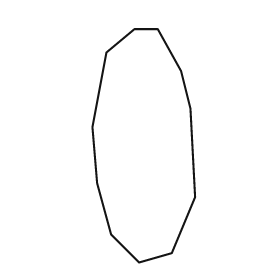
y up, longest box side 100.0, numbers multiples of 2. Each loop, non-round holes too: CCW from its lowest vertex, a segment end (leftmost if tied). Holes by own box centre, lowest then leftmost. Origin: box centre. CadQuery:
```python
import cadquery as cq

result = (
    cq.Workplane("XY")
    .moveTo(-2.0, -50.0)
    .lineTo(12.0, -46.0)
    .lineTo(22.0, -22.0)
    .lineTo(20.0, 16.0)
    .lineTo(16.0, 32.0)
    .lineTo(6.0, 50.0)
    .lineTo(-4.0, 50.0)
    .lineTo(-16.0, 40.0)
    .lineTo(-22.0, 8.0)
    .lineTo(-20.0, -16.0)
    .lineTo(-14.0, -38.0)
    .close()
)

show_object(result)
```